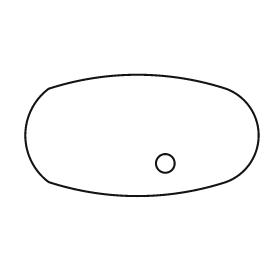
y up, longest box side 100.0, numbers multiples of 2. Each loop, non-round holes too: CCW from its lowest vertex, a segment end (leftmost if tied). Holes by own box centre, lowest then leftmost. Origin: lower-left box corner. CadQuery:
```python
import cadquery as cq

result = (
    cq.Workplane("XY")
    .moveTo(10.0, 6.0)
    .threePointArc((48.0, 0.0), (86.0, 6.0))
    .threePointArc((100.0, 26.0), (86.0, 46.0))
    .threePointArc((48.0, 52.0), (10.0, 46.0))
    .threePointArc((0.0, 26.0), (10.0, 6.0))
    .close()
    .moveTo(60.0, 14.0)
    .circle(4.0)
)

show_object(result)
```